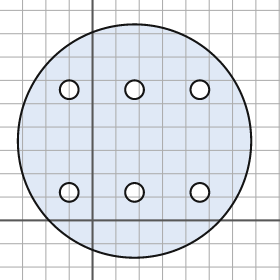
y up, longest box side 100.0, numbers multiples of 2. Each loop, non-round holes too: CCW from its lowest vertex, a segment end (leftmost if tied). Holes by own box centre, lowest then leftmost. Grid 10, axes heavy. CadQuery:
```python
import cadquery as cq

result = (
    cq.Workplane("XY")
    .moveTo(18.0, 34.0)
    .circle(50.0)
    .moveTo(-10.0, 12.0)
    .circle(4.0)
    .moveTo(18.0, 12.0)
    .circle(4.0)
    .moveTo(46.0, 12.0)
    .circle(4.0)
    .moveTo(-10.0, 56.0)
    .circle(4.0)
    .moveTo(18.0, 56.0)
    .circle(4.0)
    .moveTo(46.0, 56.0)
    .circle(4.0)
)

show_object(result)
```